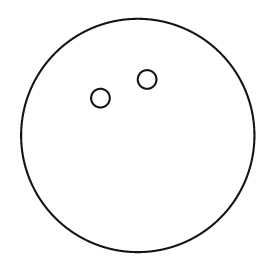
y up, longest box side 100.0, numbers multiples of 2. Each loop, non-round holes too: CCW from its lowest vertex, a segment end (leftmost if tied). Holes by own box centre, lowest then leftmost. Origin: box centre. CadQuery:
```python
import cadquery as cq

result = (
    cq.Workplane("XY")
    .moveTo(0.0, 0.0)
    .circle(50.0)
    .moveTo(-16.0, 16.0)
    .circle(4.0)
    .moveTo(4.0, 24.0)
    .circle(4.0)
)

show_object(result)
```